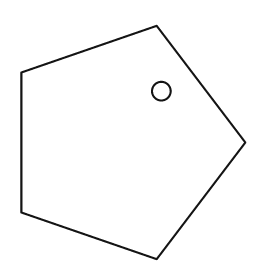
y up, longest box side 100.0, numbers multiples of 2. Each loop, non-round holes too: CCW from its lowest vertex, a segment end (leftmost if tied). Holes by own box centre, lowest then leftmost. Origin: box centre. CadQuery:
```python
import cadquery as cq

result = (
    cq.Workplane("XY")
    .moveTo(10.0, -50.0)
    .lineTo(48.0, 0.0)
    .lineTo(10.0, 50.0)
    .lineTo(-48.0, 30.0)
    .lineTo(-48.0, -30.0)
    .close()
    .moveTo(12.0, 22.0)
    .circle(4.0)
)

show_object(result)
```